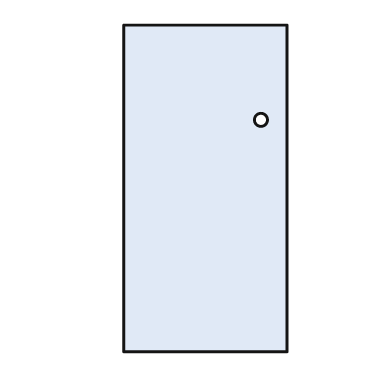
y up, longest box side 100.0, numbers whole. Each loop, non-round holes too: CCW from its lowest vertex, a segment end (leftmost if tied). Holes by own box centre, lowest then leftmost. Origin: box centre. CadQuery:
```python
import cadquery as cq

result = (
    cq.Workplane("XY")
    .moveTo(-25.0, -50.0)
    .lineTo(25.0, -50.0)
    .lineTo(25.0, 50.0)
    .lineTo(-25.0, 50.0)
    .close()
    .moveTo(17.0, 21.0)
    .circle(2.0)
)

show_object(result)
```